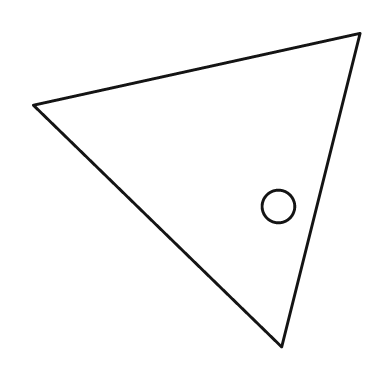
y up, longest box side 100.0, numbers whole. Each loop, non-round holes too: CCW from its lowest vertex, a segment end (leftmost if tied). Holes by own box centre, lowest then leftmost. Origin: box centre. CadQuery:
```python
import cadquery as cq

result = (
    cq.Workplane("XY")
    .moveTo(26.0, -48.0)
    .lineTo(50.0, 48.0)
    .lineTo(-50.0, 26.0)
    .close()
    .moveTo(25.0, -5.0)
    .circle(5.0)
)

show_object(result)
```